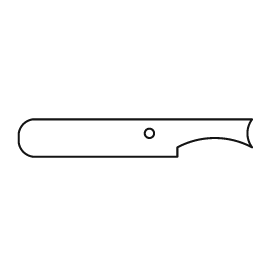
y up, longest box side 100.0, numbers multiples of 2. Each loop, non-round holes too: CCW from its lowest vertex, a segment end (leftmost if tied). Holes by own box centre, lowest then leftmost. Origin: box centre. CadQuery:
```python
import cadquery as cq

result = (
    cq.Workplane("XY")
    .moveTo(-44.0, -8.0)
    .lineTo(18.0, -8.0)
    .lineTo(18.0, -4.0)
    .threePointArc((34.0, 0.0), (50.0, -4.0))
    .threePointArc((48.0, 2.0), (50.0, 8.0))
    .lineTo(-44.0, 8.0)
    .threePointArc((-48.0, 6.0), (-50.0, 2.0))
    .lineTo(-50.0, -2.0)
    .threePointArc((-48.0, -6.0), (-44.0, -8.0))
    .close()
    .moveTo(6.0, 2.0)
    .circle(2.0)
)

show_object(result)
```